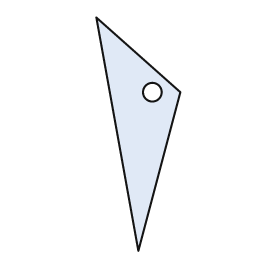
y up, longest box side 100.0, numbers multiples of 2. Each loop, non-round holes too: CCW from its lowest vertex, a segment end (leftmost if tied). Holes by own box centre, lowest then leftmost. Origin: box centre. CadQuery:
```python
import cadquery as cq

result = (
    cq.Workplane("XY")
    .moveTo(0.0, -50.0)
    .lineTo(18.0, 18.0)
    .lineTo(-18.0, 50.0)
    .close()
    .moveTo(6.0, 18.0)
    .circle(4.0)
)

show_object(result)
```